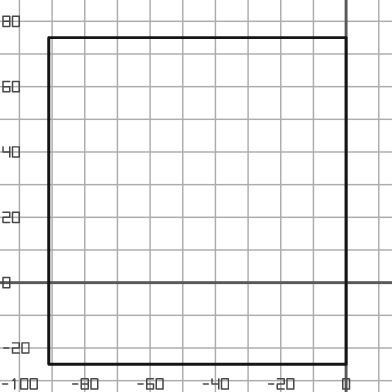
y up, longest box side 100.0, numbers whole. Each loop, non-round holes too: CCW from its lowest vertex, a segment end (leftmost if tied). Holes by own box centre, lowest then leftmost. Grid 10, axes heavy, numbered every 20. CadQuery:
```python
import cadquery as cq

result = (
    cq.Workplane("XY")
    .moveTo(-91.0, -25.0)
    .lineTo(0.0, -25.0)
    .lineTo(0.0, 75.0)
    .lineTo(-91.0, 75.0)
    .close()
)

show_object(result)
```